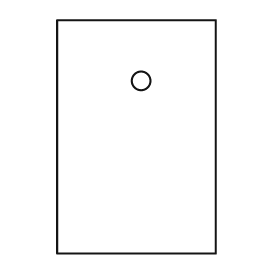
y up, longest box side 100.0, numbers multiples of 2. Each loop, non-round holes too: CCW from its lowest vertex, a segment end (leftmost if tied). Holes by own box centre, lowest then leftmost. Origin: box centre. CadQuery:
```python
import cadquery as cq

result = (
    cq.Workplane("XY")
    .moveTo(-34.0, -50.0)
    .lineTo(34.0, -50.0)
    .lineTo(34.0, 50.0)
    .lineTo(-34.0, 50.0)
    .close()
    .moveTo(2.0, 24.0)
    .circle(4.0)
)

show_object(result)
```